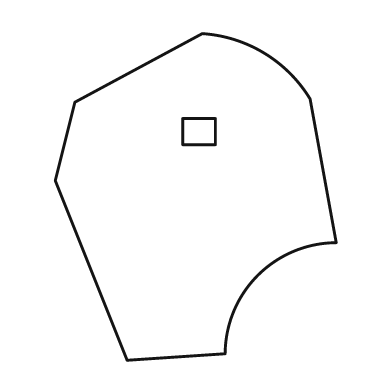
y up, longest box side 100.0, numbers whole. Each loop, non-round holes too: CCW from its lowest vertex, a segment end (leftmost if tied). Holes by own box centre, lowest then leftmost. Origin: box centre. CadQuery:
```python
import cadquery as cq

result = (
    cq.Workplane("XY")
    .moveTo(-21.0, -50.0)
    .lineTo(9.0, -48.0)
    .threePointArc((19.0, -24.0), (43.0, -14.0))
    .lineTo(35.0, 30.0)
    .threePointArc((21.0, 44.0), (2.0, 50.0))
    .lineTo(-37.0, 29.0)
    .lineTo(-43.0, 5.0)
    .close()
    .moveTo(-4.0, 16.0)
    .lineTo(6.0, 16.0)
    .lineTo(6.0, 24.0)
    .lineTo(-4.0, 24.0)
    .close()
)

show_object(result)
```